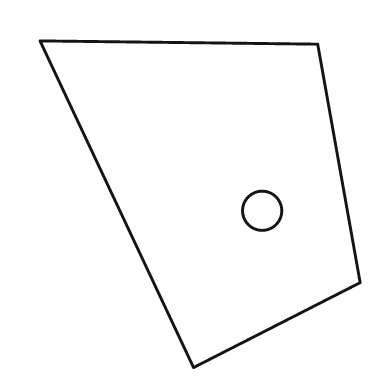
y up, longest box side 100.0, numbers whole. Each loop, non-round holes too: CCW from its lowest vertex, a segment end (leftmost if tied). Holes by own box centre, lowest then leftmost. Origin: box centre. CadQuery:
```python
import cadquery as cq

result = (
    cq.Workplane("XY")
    .moveTo(-2.0, -50.0)
    .lineTo(49.0, -24.0)
    .lineTo(36.0, 49.0)
    .lineTo(-49.0, 50.0)
    .close()
    .moveTo(19.0, -2.0)
    .circle(6.0)
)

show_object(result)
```